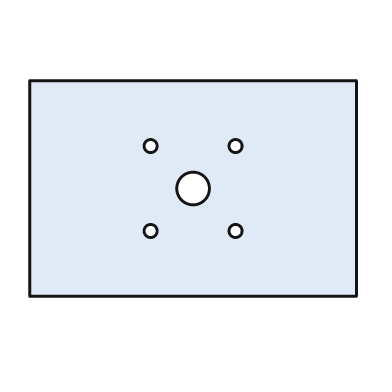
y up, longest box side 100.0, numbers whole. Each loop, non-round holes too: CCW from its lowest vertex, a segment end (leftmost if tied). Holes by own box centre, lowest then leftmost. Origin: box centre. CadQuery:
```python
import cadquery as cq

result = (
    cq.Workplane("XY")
    .moveTo(-50.0, -33.0)
    .lineTo(50.0, -33.0)
    .lineTo(50.0, 33.0)
    .lineTo(-50.0, 33.0)
    .close()
    .moveTo(-13.0, -13.0)
    .circle(2.0)
    .moveTo(13.0, -13.0)
    .circle(2.0)
    .moveTo(0.0, 0.0)
    .circle(5.0)
    .moveTo(-13.0, 13.0)
    .circle(2.0)
    .moveTo(13.0, 13.0)
    .circle(2.0)
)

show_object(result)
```